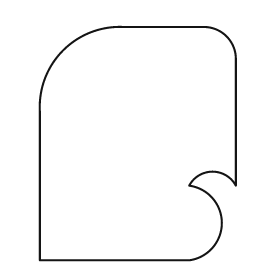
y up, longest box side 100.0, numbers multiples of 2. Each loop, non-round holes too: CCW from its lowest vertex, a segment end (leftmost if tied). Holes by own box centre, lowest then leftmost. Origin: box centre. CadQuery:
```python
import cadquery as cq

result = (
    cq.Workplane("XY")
    .moveTo(-42.0, -50.0)
    .lineTo(22.0, -50.0)
    .threePointArc((36.0, -34.0), (22.0, -18.0))
    .threePointArc((32.0, -12.0), (42.0, -18.0))
    .lineTo(42.0, 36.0)
    .threePointArc((38.0, 46.0), (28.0, 50.0))
    .lineTo(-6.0, 50.0)
    .threePointArc((-32.0, 40.0), (-42.0, 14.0))
    .close()
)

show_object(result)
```